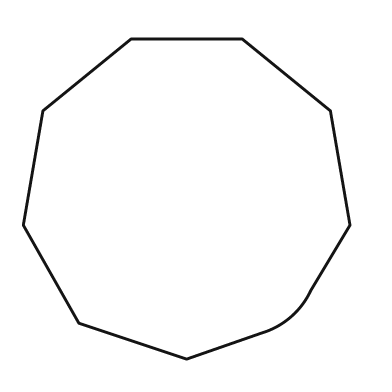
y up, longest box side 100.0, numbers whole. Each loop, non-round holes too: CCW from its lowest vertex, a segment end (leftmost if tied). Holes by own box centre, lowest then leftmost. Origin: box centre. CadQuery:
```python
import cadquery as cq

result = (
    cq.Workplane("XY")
    .moveTo(0.0, -49.0)
    .lineTo(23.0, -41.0)
    .threePointArc((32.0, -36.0), (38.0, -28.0))
    .lineTo(50.0, -8.0)
    .lineTo(44.0, 27.0)
    .lineTo(17.0, 49.0)
    .lineTo(-17.0, 49.0)
    .lineTo(-44.0, 27.0)
    .lineTo(-50.0, -8.0)
    .lineTo(-33.0, -38.0)
    .close()
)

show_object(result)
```